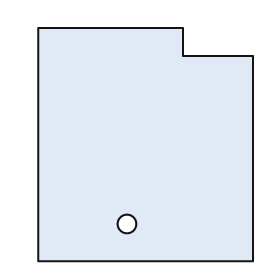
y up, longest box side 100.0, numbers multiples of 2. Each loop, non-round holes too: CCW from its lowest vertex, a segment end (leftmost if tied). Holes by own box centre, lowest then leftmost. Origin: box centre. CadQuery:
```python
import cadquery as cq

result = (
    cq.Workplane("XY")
    .moveTo(-46.0, -50.0)
    .lineTo(46.0, -50.0)
    .lineTo(46.0, 38.0)
    .lineTo(16.0, 38.0)
    .lineTo(16.0, 50.0)
    .lineTo(-46.0, 50.0)
    .close()
    .moveTo(-8.0, -34.0)
    .circle(4.0)
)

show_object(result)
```